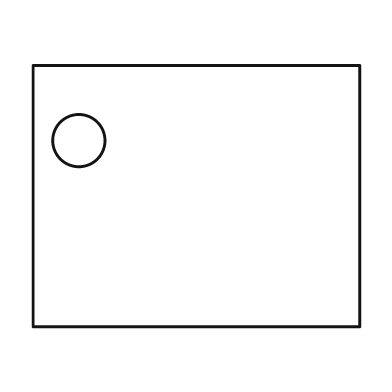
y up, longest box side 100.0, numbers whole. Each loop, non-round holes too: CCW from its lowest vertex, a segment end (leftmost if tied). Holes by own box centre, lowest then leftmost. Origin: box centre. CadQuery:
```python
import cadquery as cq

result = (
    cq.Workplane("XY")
    .moveTo(-50.0, -40.0)
    .lineTo(50.0, -40.0)
    .lineTo(50.0, 40.0)
    .lineTo(-50.0, 40.0)
    .close()
    .moveTo(-36.0, 17.0)
    .circle(8.0)
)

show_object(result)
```